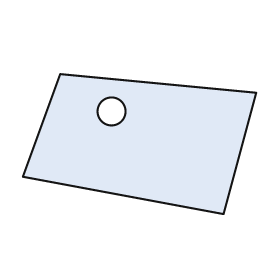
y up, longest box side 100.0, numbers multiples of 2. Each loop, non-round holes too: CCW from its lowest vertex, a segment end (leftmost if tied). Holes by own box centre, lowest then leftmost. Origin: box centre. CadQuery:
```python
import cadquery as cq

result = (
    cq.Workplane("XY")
    .moveTo(36.0, -30.0)
    .lineTo(50.0, 22.0)
    .lineTo(-34.0, 30.0)
    .lineTo(-50.0, -14.0)
    .close()
    .moveTo(-12.0, 14.0)
    .circle(6.0)
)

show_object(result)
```